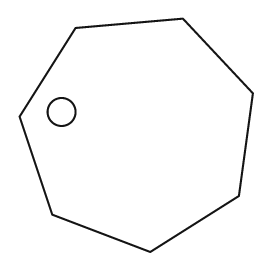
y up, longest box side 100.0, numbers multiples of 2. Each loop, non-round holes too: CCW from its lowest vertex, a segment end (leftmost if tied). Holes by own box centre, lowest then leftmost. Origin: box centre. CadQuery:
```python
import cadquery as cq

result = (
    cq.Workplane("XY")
    .moveTo(6.0, -50.0)
    .lineTo(44.0, -26.0)
    .lineTo(50.0, 18.0)
    .lineTo(20.0, 50.0)
    .lineTo(-26.0, 46.0)
    .lineTo(-50.0, 8.0)
    .lineTo(-36.0, -34.0)
    .close()
    .moveTo(-32.0, 10.0)
    .circle(6.0)
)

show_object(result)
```